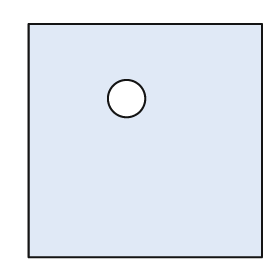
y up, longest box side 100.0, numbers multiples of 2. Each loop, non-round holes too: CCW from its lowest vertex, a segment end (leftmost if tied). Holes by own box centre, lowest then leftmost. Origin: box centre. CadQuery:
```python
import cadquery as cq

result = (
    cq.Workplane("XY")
    .moveTo(-50.0, -50.0)
    .lineTo(50.0, -50.0)
    .lineTo(50.0, 50.0)
    .lineTo(-50.0, 50.0)
    .close()
    .moveTo(-8.0, 18.0)
    .circle(8.0)
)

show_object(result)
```